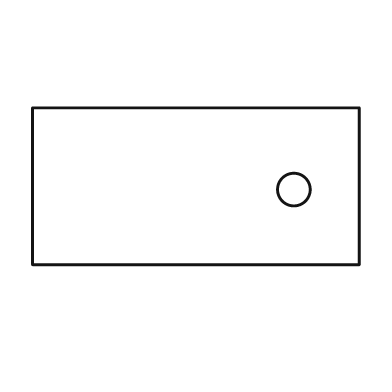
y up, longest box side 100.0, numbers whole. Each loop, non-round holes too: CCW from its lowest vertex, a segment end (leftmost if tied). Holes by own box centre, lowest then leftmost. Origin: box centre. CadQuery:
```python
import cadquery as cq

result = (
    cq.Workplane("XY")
    .moveTo(-50.0, -24.0)
    .lineTo(50.0, -24.0)
    .lineTo(50.0, 24.0)
    .lineTo(-50.0, 24.0)
    .close()
    .moveTo(30.0, -1.0)
    .circle(5.0)
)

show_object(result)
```